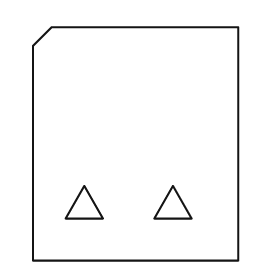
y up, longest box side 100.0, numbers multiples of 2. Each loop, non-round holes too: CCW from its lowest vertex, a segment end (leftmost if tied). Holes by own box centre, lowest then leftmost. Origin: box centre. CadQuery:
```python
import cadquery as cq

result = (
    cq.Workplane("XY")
    .moveTo(-44.0, -50.0)
    .lineTo(44.0, -50.0)
    .lineTo(44.0, 50.0)
    .lineTo(-36.0, 50.0)
    .lineTo(-44.0, 42.0)
    .close()
    .moveTo(-30.0, -32.0)
    .lineTo(-14.0, -32.0)
    .lineTo(-22.0, -18.0)
    .close()
    .moveTo(8.0, -32.0)
    .lineTo(24.0, -32.0)
    .lineTo(16.0, -18.0)
    .close()
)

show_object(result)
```